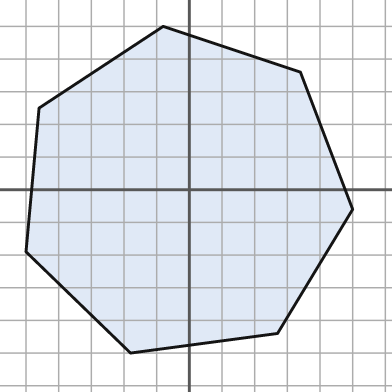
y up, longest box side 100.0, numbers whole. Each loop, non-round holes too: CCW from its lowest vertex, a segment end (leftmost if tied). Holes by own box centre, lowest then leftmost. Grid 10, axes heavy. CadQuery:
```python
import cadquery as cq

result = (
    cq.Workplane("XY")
    .moveTo(-18.0, -50.0)
    .lineTo(27.0, -44.0)
    .lineTo(50.0, -6.0)
    .lineTo(34.0, 36.0)
    .lineTo(-8.0, 50.0)
    .lineTo(-46.0, 25.0)
    .lineTo(-50.0, -19.0)
    .close()
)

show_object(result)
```